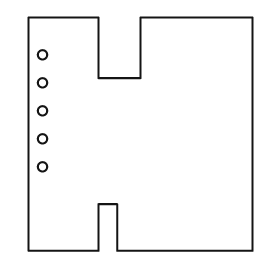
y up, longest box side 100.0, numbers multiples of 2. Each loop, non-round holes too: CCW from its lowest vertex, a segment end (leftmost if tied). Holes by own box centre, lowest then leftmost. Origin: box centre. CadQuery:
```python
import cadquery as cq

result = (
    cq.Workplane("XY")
    .moveTo(-48.0, -50.0)
    .lineTo(-18.0, -50.0)
    .lineTo(-18.0, -30.0)
    .lineTo(-10.0, -30.0)
    .lineTo(-10.0, -50.0)
    .lineTo(48.0, -50.0)
    .lineTo(48.0, 50.0)
    .lineTo(0.0, 50.0)
    .lineTo(0.0, 24.0)
    .lineTo(-18.0, 24.0)
    .lineTo(-18.0, 50.0)
    .lineTo(-48.0, 50.0)
    .close()
    .moveTo(-42.0, -14.0)
    .circle(2.0)
    .moveTo(-42.0, -2.0)
    .circle(2.0)
    .moveTo(-42.0, 10.0)
    .circle(2.0)
    .moveTo(-42.0, 22.0)
    .circle(2.0)
    .moveTo(-42.0, 34.0)
    .circle(2.0)
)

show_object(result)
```